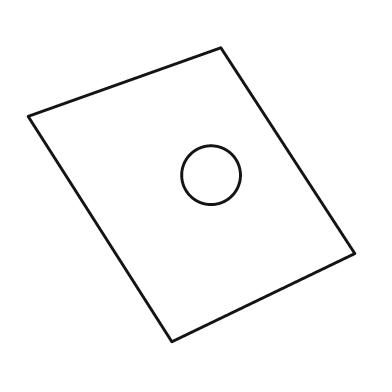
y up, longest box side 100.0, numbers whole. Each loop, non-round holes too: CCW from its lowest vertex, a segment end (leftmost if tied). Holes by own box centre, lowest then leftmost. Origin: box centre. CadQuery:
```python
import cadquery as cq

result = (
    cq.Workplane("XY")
    .moveTo(-6.0, -45.0)
    .lineTo(50.0, -18.0)
    .lineTo(9.0, 45.0)
    .lineTo(-50.0, 24.0)
    .close()
    .moveTo(6.0, 6.0)
    .circle(9.0)
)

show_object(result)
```